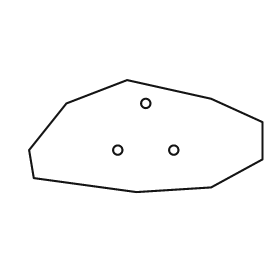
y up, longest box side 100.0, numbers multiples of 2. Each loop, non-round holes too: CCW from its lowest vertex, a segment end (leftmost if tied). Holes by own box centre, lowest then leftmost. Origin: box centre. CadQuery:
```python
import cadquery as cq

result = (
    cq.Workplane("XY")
    .moveTo(-4.0, -24.0)
    .lineTo(28.0, -22.0)
    .lineTo(50.0, -10.0)
    .lineTo(50.0, 6.0)
    .lineTo(28.0, 16.0)
    .lineTo(-8.0, 24.0)
    .lineTo(-34.0, 14.0)
    .lineTo(-50.0, -6.0)
    .lineTo(-48.0, -18.0)
    .close()
    .moveTo(-12.0, -6.0)
    .circle(2.0)
    .moveTo(12.0, -6.0)
    .circle(2.0)
    .moveTo(0.0, 14.0)
    .circle(2.0)
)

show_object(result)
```